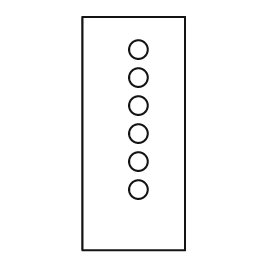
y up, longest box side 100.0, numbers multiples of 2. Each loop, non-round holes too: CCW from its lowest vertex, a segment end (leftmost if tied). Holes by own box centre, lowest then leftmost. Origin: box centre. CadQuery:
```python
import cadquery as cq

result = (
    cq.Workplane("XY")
    .moveTo(-22.0, -50.0)
    .lineTo(22.0, -50.0)
    .lineTo(22.0, 50.0)
    .lineTo(-22.0, 50.0)
    .close()
    .moveTo(2.0, -24.0)
    .circle(4.0)
    .moveTo(2.0, -12.0)
    .circle(4.0)
    .moveTo(2.0, 0.0)
    .circle(4.0)
    .moveTo(2.0, 12.0)
    .circle(4.0)
    .moveTo(2.0, 24.0)
    .circle(4.0)
    .moveTo(2.0, 36.0)
    .circle(4.0)
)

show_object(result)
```